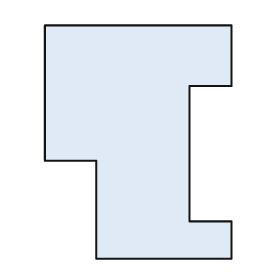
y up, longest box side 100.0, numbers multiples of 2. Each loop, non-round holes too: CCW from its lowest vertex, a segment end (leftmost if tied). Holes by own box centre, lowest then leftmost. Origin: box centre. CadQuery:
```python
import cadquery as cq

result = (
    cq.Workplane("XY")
    .moveTo(-18.0, -50.0)
    .lineTo(40.0, -50.0)
    .lineTo(40.0, -34.0)
    .lineTo(22.0, -34.0)
    .lineTo(22.0, 24.0)
    .lineTo(40.0, 24.0)
    .lineTo(40.0, 50.0)
    .lineTo(-40.0, 50.0)
    .lineTo(-40.0, -8.0)
    .lineTo(-18.0, -8.0)
    .close()
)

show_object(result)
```